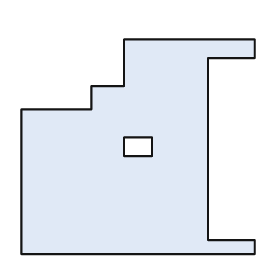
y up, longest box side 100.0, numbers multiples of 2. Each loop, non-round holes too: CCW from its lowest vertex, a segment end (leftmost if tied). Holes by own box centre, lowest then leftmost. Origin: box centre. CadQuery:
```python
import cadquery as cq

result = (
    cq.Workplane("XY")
    .moveTo(-50.0, -46.0)
    .lineTo(50.0, -46.0)
    .lineTo(50.0, -40.0)
    .lineTo(30.0, -40.0)
    .lineTo(30.0, 38.0)
    .lineTo(50.0, 38.0)
    .lineTo(50.0, 46.0)
    .lineTo(-6.0, 46.0)
    .lineTo(-6.0, 26.0)
    .lineTo(-20.0, 26.0)
    .lineTo(-20.0, 16.0)
    .lineTo(-50.0, 16.0)
    .close()
    .moveTo(-6.0, -4.0)
    .lineTo(6.0, -4.0)
    .lineTo(6.0, 4.0)
    .lineTo(-6.0, 4.0)
    .close()
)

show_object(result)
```